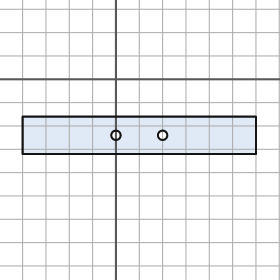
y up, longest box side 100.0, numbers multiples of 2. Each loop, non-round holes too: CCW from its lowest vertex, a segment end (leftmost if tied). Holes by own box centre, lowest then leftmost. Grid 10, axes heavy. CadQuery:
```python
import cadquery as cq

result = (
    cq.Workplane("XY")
    .moveTo(-40.0, -32.0)
    .lineTo(60.0, -32.0)
    .lineTo(60.0, -16.0)
    .lineTo(-40.0, -16.0)
    .close()
    .moveTo(0.0, -24.0)
    .circle(2.0)
    .moveTo(20.0, -24.0)
    .circle(2.0)
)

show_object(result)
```